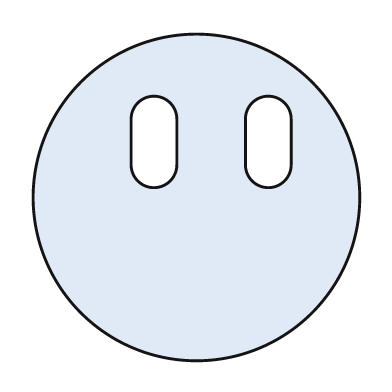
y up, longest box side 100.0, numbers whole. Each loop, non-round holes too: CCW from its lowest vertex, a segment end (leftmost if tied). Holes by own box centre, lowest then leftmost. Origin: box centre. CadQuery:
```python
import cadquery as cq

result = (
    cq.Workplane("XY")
    .moveTo(0.0, 0.0)
    .circle(50.0)
    .moveTo(-20.0, 10.0)
    .threePointArc((-13.0, 3.0), (-6.0, 10.0))
    .lineTo(-6.0, 24.0)
    .threePointArc((-13.0, 31.0), (-20.0, 24.0))
    .close()
    .moveTo(15.0, 10.0)
    .threePointArc((22.0, 3.0), (29.0, 10.0))
    .lineTo(29.0, 24.0)
    .threePointArc((22.0, 31.0), (15.0, 24.0))
    .close()
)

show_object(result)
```